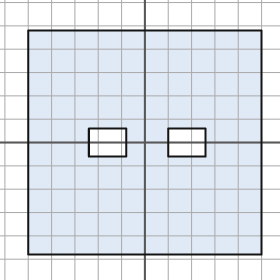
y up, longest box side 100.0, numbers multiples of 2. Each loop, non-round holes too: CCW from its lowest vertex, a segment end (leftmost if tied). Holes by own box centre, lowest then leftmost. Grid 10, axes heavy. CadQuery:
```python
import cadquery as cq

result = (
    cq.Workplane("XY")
    .moveTo(-50.0, -48.0)
    .lineTo(50.0, -48.0)
    .lineTo(50.0, 48.0)
    .lineTo(-50.0, 48.0)
    .close()
    .moveTo(-24.0, -6.0)
    .lineTo(-8.0, -6.0)
    .lineTo(-8.0, 6.0)
    .lineTo(-24.0, 6.0)
    .close()
    .moveTo(10.0, -6.0)
    .lineTo(26.0, -6.0)
    .lineTo(26.0, 6.0)
    .lineTo(10.0, 6.0)
    .close()
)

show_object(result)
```